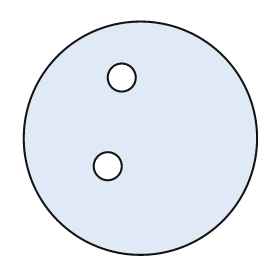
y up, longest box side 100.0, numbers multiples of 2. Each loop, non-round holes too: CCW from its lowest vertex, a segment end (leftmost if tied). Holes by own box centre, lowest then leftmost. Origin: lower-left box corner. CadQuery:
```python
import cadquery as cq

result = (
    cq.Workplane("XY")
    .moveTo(50.0, 50.0)
    .circle(50.0)
    .moveTo(36.0, 38.0)
    .circle(6.0)
    .moveTo(42.0, 76.0)
    .circle(6.0)
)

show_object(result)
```